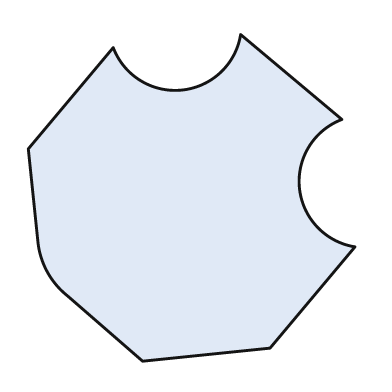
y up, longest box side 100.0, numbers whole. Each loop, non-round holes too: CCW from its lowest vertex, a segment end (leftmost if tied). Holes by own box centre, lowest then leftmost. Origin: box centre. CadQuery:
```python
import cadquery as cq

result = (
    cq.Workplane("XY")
    .moveTo(-15.0, -50.0)
    .lineTo(24.0, -46.0)
    .lineTo(50.0, -15.0)
    .threePointArc((33.0, 3.0), (46.0, 24.0))
    .lineTo(15.0, 50.0)
    .threePointArc((-3.0, 33.0), (-24.0, 46.0))
    .lineTo(-50.0, 15.0)
    .lineTo(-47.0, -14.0)
    .threePointArc((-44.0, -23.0), (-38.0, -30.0))
    .close()
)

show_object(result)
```